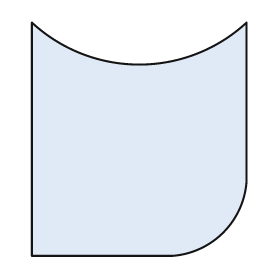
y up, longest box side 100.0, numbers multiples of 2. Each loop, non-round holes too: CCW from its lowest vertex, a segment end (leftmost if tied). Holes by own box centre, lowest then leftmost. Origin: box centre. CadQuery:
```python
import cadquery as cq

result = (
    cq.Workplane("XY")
    .moveTo(-46.0, -50.0)
    .lineTo(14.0, -50.0)
    .threePointArc((36.0, -40.0), (46.0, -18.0))
    .lineTo(46.0, 50.0)
    .threePointArc((0.0, 32.0), (-46.0, 50.0))
    .close()
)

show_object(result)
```